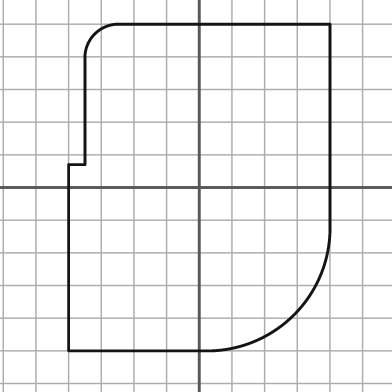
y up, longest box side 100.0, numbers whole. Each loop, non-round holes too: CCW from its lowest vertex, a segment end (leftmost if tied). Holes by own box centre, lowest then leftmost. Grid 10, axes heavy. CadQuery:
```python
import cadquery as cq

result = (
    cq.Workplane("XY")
    .moveTo(-40.0, -50.0)
    .lineTo(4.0, -50.0)
    .threePointArc((29.0, -39.0), (40.0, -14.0))
    .lineTo(40.0, 50.0)
    .lineTo(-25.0, 50.0)
    .threePointArc((-32.0, 47.0), (-35.0, 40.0))
    .lineTo(-35.0, 7.0)
    .lineTo(-40.0, 7.0)
    .close()
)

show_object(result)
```